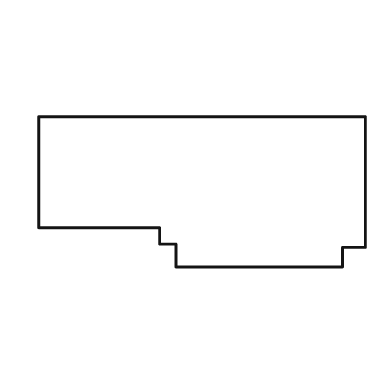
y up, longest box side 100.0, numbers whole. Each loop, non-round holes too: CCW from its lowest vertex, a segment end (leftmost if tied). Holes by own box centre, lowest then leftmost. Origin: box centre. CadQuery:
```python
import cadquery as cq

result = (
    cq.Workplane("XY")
    .moveTo(-8.0, -23.0)
    .lineTo(43.0, -23.0)
    .lineTo(43.0, -17.0)
    .lineTo(50.0, -17.0)
    .lineTo(50.0, 23.0)
    .lineTo(-50.0, 23.0)
    .lineTo(-50.0, -11.0)
    .lineTo(-13.0, -11.0)
    .lineTo(-13.0, -16.0)
    .lineTo(-8.0, -16.0)
    .close()
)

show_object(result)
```